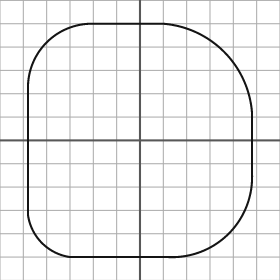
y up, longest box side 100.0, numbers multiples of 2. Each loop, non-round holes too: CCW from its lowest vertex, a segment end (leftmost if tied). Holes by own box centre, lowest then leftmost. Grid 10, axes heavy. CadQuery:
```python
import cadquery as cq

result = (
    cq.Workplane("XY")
    .moveTo(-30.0, -50.0)
    .lineTo(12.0, -50.0)
    .threePointArc((38.0, -40.0), (48.0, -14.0))
    .lineTo(48.0, 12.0)
    .threePointArc((36.0, 38.0), (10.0, 50.0))
    .lineTo(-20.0, 50.0)
    .threePointArc((-40.0, 42.0), (-48.0, 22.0))
    .lineTo(-48.0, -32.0)
    .threePointArc((-42.0, -44.0), (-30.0, -50.0))
    .close()
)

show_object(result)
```